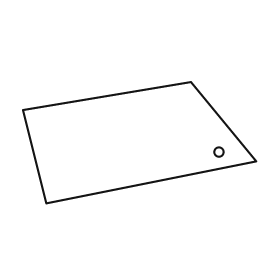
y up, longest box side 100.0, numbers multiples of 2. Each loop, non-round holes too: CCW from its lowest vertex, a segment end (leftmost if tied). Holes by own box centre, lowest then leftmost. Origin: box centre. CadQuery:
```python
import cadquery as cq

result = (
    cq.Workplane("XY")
    .moveTo(-40.0, -26.0)
    .lineTo(50.0, -8.0)
    .lineTo(22.0, 26.0)
    .lineTo(-50.0, 14.0)
    .close()
    .moveTo(34.0, -4.0)
    .circle(2.0)
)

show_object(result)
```